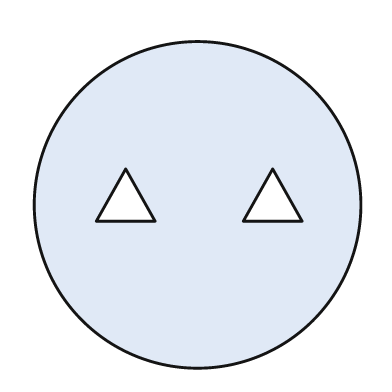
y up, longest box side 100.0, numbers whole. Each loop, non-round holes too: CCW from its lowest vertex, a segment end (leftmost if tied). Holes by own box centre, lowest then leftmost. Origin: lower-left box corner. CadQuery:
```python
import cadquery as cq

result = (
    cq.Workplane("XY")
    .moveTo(50.0, 50.0)
    .circle(50.0)
    .moveTo(19.0, 45.0)
    .lineTo(37.0, 45.0)
    .lineTo(28.0, 61.0)
    .close()
    .moveTo(64.0, 45.0)
    .lineTo(82.0, 45.0)
    .lineTo(73.0, 61.0)
    .close()
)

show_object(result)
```